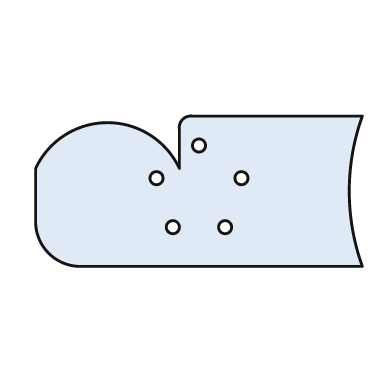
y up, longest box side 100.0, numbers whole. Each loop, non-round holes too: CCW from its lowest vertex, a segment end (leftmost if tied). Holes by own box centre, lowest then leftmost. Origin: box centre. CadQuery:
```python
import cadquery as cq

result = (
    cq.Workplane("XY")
    .moveTo(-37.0, -23.0)
    .lineTo(50.0, -23.0)
    .threePointArc((46.0, 0.0), (50.0, 23.0))
    .lineTo(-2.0, 23.0)
    .threePointArc((-5.0, 22.0), (-6.0, 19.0))
    .lineTo(-6.0, 7.0)
    .threePointArc((-28.0, 21.0), (-50.0, 7.0))
    .lineTo(-50.0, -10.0)
    .threePointArc((-46.0, -19.0), (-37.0, -23.0))
    .close()
    .moveTo(-8.0, -11.0)
    .circle(2.0)
    .moveTo(8.0, -11.0)
    .circle(2.0)
    .moveTo(-13.0, 4.0)
    .circle(2.0)
    .moveTo(13.0, 4.0)
    .circle(2.0)
    .moveTo(0.0, 14.0)
    .circle(2.0)
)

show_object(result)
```